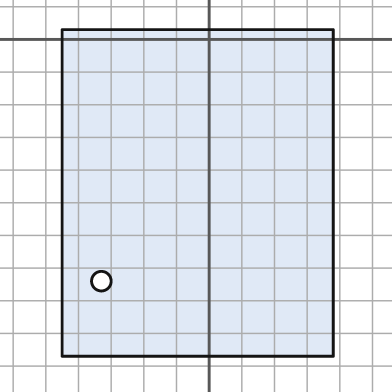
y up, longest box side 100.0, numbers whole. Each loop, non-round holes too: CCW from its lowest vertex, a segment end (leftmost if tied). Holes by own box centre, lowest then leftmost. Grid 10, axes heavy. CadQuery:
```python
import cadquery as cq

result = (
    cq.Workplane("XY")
    .moveTo(-45.0, -97.0)
    .lineTo(38.0, -97.0)
    .lineTo(38.0, 3.0)
    .lineTo(-45.0, 3.0)
    .close()
    .moveTo(-33.0, -74.0)
    .circle(3.0)
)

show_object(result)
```